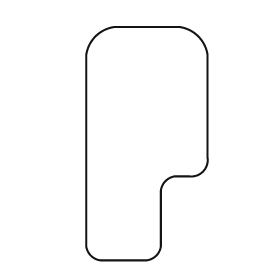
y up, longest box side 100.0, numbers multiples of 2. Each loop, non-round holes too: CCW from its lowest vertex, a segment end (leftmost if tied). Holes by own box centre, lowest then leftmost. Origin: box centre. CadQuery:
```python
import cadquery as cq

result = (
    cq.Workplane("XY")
    .moveTo(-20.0, -50.0)
    .lineTo(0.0, -50.0)
    .threePointArc((4.0, -48.0), (6.0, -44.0))
    .lineTo(6.0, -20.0)
    .threePointArc((8.0, -16.0), (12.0, -14.0))
    .lineTo(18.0, -14.0)
    .threePointArc((24.0, -12.0), (26.0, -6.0))
    .lineTo(26.0, 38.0)
    .threePointArc((22.0, 46.0), (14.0, 50.0))
    .lineTo(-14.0, 50.0)
    .threePointArc((-22.0, 46.0), (-26.0, 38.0))
    .lineTo(-26.0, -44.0)
    .threePointArc((-24.0, -48.0), (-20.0, -50.0))
    .close()
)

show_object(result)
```